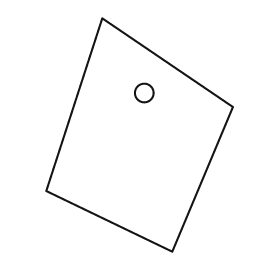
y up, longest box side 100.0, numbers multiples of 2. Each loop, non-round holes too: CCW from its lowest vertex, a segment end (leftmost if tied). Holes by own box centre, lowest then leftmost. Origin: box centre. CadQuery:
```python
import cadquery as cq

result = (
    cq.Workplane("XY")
    .moveTo(14.0, -50.0)
    .lineTo(40.0, 12.0)
    .lineTo(-16.0, 50.0)
    .lineTo(-40.0, -24.0)
    .close()
    .moveTo(2.0, 18.0)
    .circle(4.0)
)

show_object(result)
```